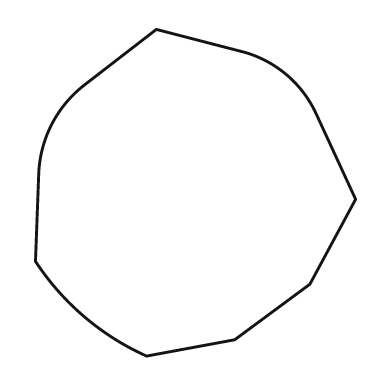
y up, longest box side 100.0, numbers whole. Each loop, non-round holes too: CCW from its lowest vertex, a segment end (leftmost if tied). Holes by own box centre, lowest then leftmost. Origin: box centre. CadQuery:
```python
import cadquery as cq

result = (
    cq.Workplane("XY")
    .moveTo(-15.0, -50.0)
    .lineTo(12.0, -45.0)
    .lineTo(35.0, -28.0)
    .lineTo(49.0, -2.0)
    .lineTo(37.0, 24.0)
    .threePointArc((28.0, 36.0), (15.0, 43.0))
    .lineTo(-12.0, 50.0)
    .lineTo(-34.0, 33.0)
    .threePointArc((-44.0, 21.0), (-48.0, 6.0))
    .lineTo(-49.0, -21.0)
    .threePointArc((-34.0, -38.0), (-15.0, -50.0))
    .close()
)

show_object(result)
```